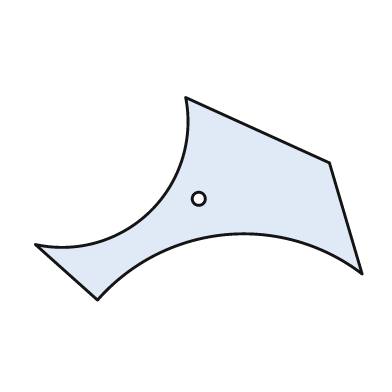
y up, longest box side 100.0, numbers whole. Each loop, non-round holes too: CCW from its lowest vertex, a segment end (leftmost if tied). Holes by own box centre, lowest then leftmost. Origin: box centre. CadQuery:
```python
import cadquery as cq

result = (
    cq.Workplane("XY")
    .moveTo(-31.0, -31.0)
    .threePointArc((8.0, -11.0), (50.0, -23.0))
    .lineTo(40.0, 11.0)
    .lineTo(-4.0, 31.0)
    .threePointArc((-15.0, -4.0), (-50.0, -14.0))
    .close()
    .moveTo(0.0, 0.0)
    .circle(2.0)
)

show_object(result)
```